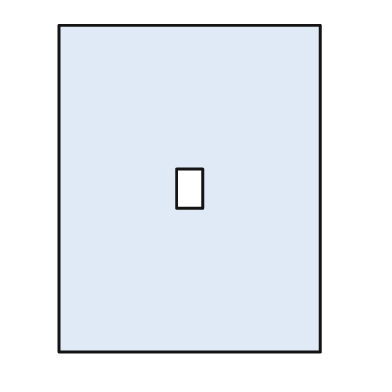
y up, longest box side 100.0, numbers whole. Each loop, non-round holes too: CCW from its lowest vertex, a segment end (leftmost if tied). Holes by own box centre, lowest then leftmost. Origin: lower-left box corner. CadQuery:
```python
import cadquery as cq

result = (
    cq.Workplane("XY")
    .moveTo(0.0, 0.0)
    .lineTo(80.0, 0.0)
    .lineTo(80.0, 100.0)
    .lineTo(0.0, 100.0)
    .close()
    .moveTo(36.0, 44.0)
    .lineTo(44.0, 44.0)
    .lineTo(44.0, 56.0)
    .lineTo(36.0, 56.0)
    .close()
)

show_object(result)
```